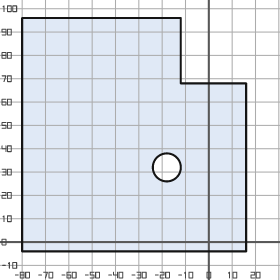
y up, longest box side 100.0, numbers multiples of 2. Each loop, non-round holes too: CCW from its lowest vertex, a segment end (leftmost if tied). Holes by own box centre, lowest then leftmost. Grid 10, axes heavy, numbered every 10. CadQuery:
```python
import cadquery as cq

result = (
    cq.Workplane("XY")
    .moveTo(-80.0, -4.0)
    .lineTo(16.0, -4.0)
    .lineTo(16.0, 68.0)
    .lineTo(-12.0, 68.0)
    .lineTo(-12.0, 96.0)
    .lineTo(-80.0, 96.0)
    .close()
    .moveTo(-18.0, 32.0)
    .circle(6.0)
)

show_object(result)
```